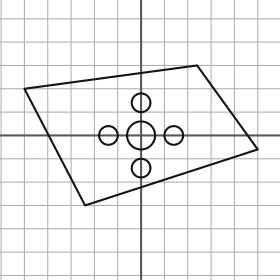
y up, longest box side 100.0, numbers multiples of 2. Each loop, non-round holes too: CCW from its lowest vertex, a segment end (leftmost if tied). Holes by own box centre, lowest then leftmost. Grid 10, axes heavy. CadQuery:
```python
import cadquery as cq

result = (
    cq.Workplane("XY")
    .moveTo(-24.0, -30.0)
    .lineTo(50.0, -6.0)
    .lineTo(24.0, 30.0)
    .lineTo(-50.0, 20.0)
    .close()
    .moveTo(0.0, -14.0)
    .circle(4.0)
    .moveTo(-14.0, 0.0)
    .circle(4.0)
    .moveTo(0.0, 0.0)
    .circle(6.0)
    .moveTo(14.0, 0.0)
    .circle(4.0)
    .moveTo(0.0, 14.0)
    .circle(4.0)
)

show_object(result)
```